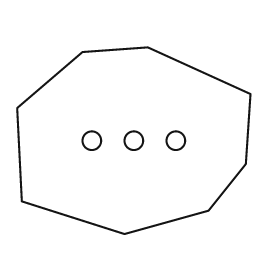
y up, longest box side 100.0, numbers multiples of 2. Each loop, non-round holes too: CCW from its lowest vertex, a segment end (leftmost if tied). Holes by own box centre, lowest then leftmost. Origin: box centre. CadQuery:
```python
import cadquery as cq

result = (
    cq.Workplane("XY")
    .moveTo(-4.0, -40.0)
    .lineTo(32.0, -30.0)
    .lineTo(48.0, -10.0)
    .lineTo(50.0, 20.0)
    .lineTo(6.0, 40.0)
    .lineTo(-22.0, 38.0)
    .lineTo(-50.0, 14.0)
    .lineTo(-48.0, -26.0)
    .close()
    .moveTo(-18.0, 0.0)
    .circle(4.0)
    .moveTo(0.0, 0.0)
    .circle(4.0)
    .moveTo(18.0, 0.0)
    .circle(4.0)
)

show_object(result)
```